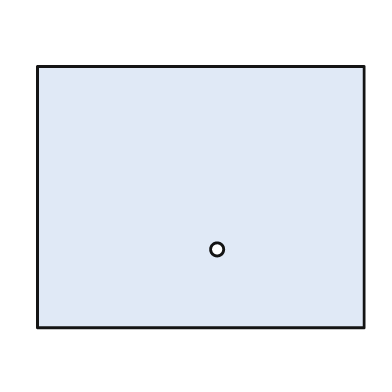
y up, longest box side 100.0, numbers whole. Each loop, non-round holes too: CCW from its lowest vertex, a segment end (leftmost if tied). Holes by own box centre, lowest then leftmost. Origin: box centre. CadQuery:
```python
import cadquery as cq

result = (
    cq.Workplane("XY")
    .moveTo(-50.0, -40.0)
    .lineTo(50.0, -40.0)
    .lineTo(50.0, 40.0)
    .lineTo(-50.0, 40.0)
    .close()
    .moveTo(5.0, -16.0)
    .circle(2.0)
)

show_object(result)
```